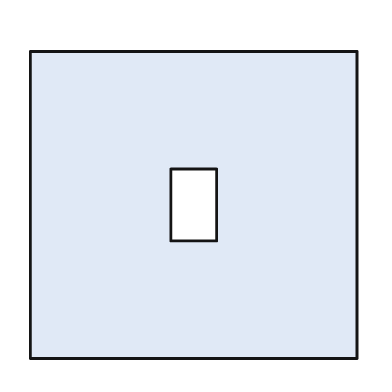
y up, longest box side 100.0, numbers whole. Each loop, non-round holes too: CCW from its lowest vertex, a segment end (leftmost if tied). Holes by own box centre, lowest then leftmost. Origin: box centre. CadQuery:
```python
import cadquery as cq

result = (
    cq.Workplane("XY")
    .moveTo(-50.0, -47.0)
    .lineTo(50.0, -47.0)
    .lineTo(50.0, 47.0)
    .lineTo(-50.0, 47.0)
    .close()
    .moveTo(-7.0, -11.0)
    .lineTo(7.0, -11.0)
    .lineTo(7.0, 11.0)
    .lineTo(-7.0, 11.0)
    .close()
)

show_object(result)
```